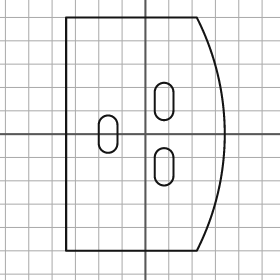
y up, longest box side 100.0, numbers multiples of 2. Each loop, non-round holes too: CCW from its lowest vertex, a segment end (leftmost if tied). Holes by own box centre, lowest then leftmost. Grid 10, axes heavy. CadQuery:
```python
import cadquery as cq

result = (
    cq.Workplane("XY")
    .moveTo(-34.0, -50.0)
    .lineTo(22.0, -50.0)
    .threePointArc((34.0, 0.0), (22.0, 50.0))
    .lineTo(-34.0, 50.0)
    .close()
    .moveTo(4.0, -18.0)
    .threePointArc((8.0, -22.0), (12.0, -18.0))
    .lineTo(12.0, -10.0)
    .threePointArc((8.0, -6.0), (4.0, -10.0))
    .close()
    .moveTo(-20.0, -4.0)
    .threePointArc((-16.0, -8.0), (-12.0, -4.0))
    .lineTo(-12.0, 4.0)
    .threePointArc((-16.0, 8.0), (-20.0, 4.0))
    .close()
    .moveTo(4.0, 10.0)
    .threePointArc((8.0, 6.0), (12.0, 10.0))
    .lineTo(12.0, 18.0)
    .threePointArc((8.0, 22.0), (4.0, 18.0))
    .close()
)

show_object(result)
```